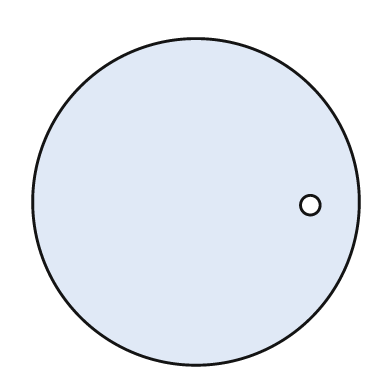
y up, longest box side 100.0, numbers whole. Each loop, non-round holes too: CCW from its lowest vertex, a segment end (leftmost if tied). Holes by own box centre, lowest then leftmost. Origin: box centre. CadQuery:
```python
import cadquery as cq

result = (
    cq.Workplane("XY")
    .moveTo(0.0, 0.0)
    .circle(50.0)
    .moveTo(35.0, -1.0)
    .circle(3.0)
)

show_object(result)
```